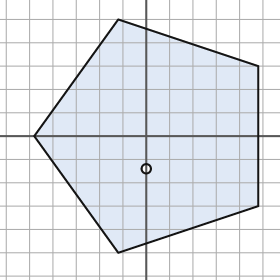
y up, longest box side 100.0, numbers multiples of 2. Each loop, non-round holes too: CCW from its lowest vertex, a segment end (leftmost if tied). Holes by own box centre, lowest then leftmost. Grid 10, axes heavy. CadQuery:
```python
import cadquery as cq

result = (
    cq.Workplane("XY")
    .moveTo(-12.0, -50.0)
    .lineTo(48.0, -30.0)
    .lineTo(48.0, 30.0)
    .lineTo(-12.0, 50.0)
    .lineTo(-48.0, 0.0)
    .close()
    .moveTo(0.0, -14.0)
    .circle(2.0)
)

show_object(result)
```